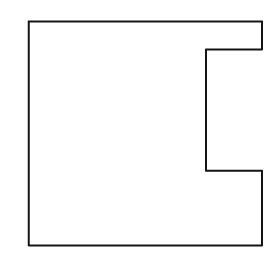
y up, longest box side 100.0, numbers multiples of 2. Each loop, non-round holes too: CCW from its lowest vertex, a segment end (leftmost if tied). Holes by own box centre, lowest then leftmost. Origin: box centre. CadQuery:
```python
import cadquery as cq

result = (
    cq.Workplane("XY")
    .moveTo(-50.0, -48.0)
    .lineTo(50.0, -48.0)
    .lineTo(50.0, -16.0)
    .lineTo(26.0, -16.0)
    .lineTo(26.0, 36.0)
    .lineTo(50.0, 36.0)
    .lineTo(50.0, 48.0)
    .lineTo(-50.0, 48.0)
    .close()
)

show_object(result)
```